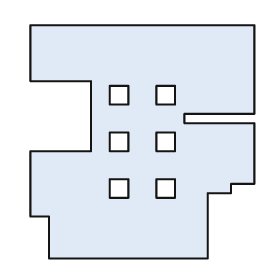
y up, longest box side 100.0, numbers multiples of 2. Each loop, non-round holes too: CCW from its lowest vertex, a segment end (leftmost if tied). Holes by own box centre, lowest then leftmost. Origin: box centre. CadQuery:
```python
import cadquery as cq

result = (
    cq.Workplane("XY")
    .moveTo(-40.0, -50.0)
    .lineTo(28.0, -50.0)
    .lineTo(28.0, -22.0)
    .lineTo(38.0, -22.0)
    .lineTo(38.0, -18.0)
    .lineTo(48.0, -18.0)
    .lineTo(48.0, 8.0)
    .lineTo(18.0, 8.0)
    .lineTo(18.0, 12.0)
    .lineTo(48.0, 12.0)
    .lineTo(48.0, 50.0)
    .lineTo(-48.0, 50.0)
    .lineTo(-48.0, 26.0)
    .lineTo(-22.0, 26.0)
    .lineTo(-22.0, -4.0)
    .lineTo(-48.0, -4.0)
    .lineTo(-48.0, -32.0)
    .lineTo(-40.0, -32.0)
    .close()
    .moveTo(-14.0, -24.0)
    .lineTo(-6.0, -24.0)
    .lineTo(-6.0, -16.0)
    .lineTo(-14.0, -16.0)
    .close()
    .moveTo(6.0, -24.0)
    .lineTo(14.0, -24.0)
    .lineTo(14.0, -16.0)
    .lineTo(6.0, -16.0)
    .close()
    .moveTo(-14.0, -4.0)
    .lineTo(-6.0, -4.0)
    .lineTo(-6.0, 4.0)
    .lineTo(-14.0, 4.0)
    .close()
    .moveTo(6.0, -4.0)
    .lineTo(14.0, -4.0)
    .lineTo(14.0, 4.0)
    .lineTo(6.0, 4.0)
    .close()
    .moveTo(-14.0, 16.0)
    .lineTo(-6.0, 16.0)
    .lineTo(-6.0, 24.0)
    .lineTo(-14.0, 24.0)
    .close()
    .moveTo(6.0, 16.0)
    .lineTo(14.0, 16.0)
    .lineTo(14.0, 24.0)
    .lineTo(6.0, 24.0)
    .close()
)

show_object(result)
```